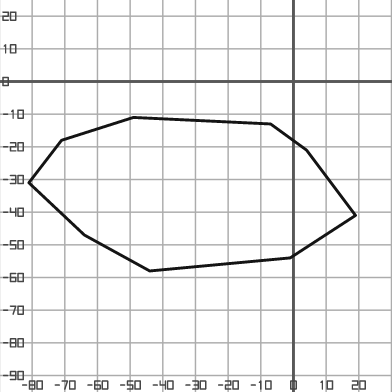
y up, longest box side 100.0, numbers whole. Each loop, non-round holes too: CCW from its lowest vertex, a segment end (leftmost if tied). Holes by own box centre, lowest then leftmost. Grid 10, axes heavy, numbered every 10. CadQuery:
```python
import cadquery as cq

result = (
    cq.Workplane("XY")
    .moveTo(-44.0, -58.0)
    .lineTo(-1.0, -54.0)
    .lineTo(19.0, -41.0)
    .lineTo(4.0, -21.0)
    .lineTo(-7.0, -13.0)
    .lineTo(-49.0, -11.0)
    .lineTo(-71.0, -18.0)
    .lineTo(-81.0, -31.0)
    .lineTo(-64.0, -47.0)
    .close()
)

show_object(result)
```